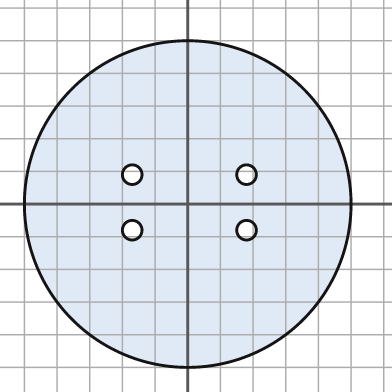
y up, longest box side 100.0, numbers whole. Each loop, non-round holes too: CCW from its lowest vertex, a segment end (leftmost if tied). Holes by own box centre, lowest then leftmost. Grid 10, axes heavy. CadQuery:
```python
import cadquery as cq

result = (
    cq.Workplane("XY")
    .moveTo(0.0, 0.0)
    .circle(50.0)
    .moveTo(-17.0, -8.0)
    .circle(3.0)
    .moveTo(18.0, -8.0)
    .circle(3.0)
    .moveTo(-17.0, 9.0)
    .circle(3.0)
    .moveTo(18.0, 9.0)
    .circle(3.0)
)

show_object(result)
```